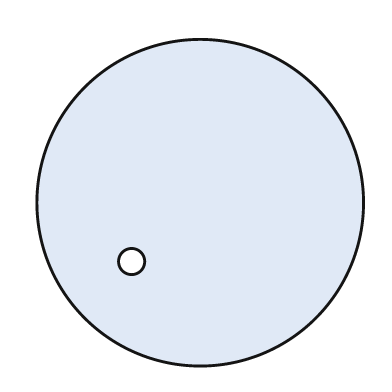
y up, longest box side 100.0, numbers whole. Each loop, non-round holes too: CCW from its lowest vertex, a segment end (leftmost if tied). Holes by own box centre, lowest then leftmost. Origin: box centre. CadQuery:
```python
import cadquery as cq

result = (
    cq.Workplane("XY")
    .moveTo(0.0, 0.0)
    .circle(50.0)
    .moveTo(-21.0, -18.0)
    .circle(4.0)
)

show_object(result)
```